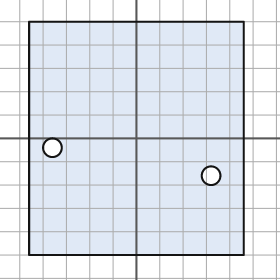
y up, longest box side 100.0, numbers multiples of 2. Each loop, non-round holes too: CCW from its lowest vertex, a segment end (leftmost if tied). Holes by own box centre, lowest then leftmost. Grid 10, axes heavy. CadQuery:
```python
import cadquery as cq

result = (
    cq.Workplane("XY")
    .moveTo(-46.0, -50.0)
    .lineTo(46.0, -50.0)
    .lineTo(46.0, 50.0)
    .lineTo(-46.0, 50.0)
    .close()
    .moveTo(32.0, -16.0)
    .circle(4.0)
    .moveTo(-36.0, -4.0)
    .circle(4.0)
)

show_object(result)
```